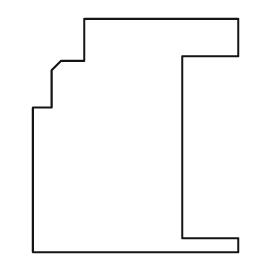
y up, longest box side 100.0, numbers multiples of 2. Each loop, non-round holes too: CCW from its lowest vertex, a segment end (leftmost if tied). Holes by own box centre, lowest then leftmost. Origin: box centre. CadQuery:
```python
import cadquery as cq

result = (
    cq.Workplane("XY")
    .moveTo(-44.0, -50.0)
    .lineTo(44.0, -50.0)
    .lineTo(44.0, -44.0)
    .lineTo(20.0, -44.0)
    .lineTo(20.0, 34.0)
    .lineTo(44.0, 34.0)
    .lineTo(44.0, 50.0)
    .lineTo(-22.0, 50.0)
    .lineTo(-22.0, 32.0)
    .lineTo(-32.0, 32.0)
    .lineTo(-36.0, 28.0)
    .lineTo(-36.0, 12.0)
    .lineTo(-44.0, 12.0)
    .close()
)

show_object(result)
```